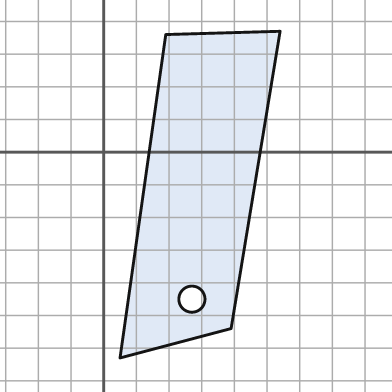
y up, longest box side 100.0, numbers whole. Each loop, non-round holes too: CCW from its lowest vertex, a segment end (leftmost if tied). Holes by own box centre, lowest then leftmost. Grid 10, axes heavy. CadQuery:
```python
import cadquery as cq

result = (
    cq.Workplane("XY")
    .moveTo(5.0, -63.0)
    .lineTo(39.0, -54.0)
    .lineTo(54.0, 37.0)
    .lineTo(19.0, 36.0)
    .close()
    .moveTo(27.0, -45.0)
    .circle(4.0)
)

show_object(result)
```